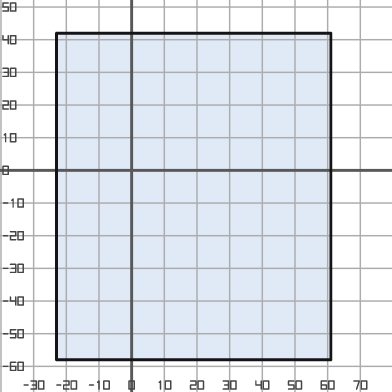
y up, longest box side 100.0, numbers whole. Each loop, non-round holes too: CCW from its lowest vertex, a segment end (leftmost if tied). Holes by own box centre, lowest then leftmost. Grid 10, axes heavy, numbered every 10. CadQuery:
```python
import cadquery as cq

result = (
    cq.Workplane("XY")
    .moveTo(-23.0, -58.0)
    .lineTo(61.0, -58.0)
    .lineTo(61.0, 42.0)
    .lineTo(-23.0, 42.0)
    .close()
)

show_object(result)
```